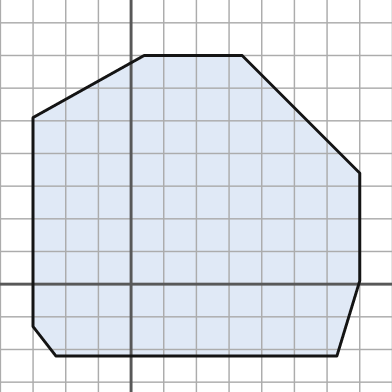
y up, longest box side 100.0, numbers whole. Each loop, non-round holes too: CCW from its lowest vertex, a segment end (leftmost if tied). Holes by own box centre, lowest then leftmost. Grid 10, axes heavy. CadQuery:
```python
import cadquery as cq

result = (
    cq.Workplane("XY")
    .moveTo(-23.0, -22.0)
    .lineTo(63.0, -22.0)
    .lineTo(70.0, 1.0)
    .lineTo(70.0, 34.0)
    .lineTo(34.0, 70.0)
    .lineTo(4.0, 70.0)
    .lineTo(-30.0, 51.0)
    .lineTo(-30.0, -13.0)
    .close()
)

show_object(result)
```